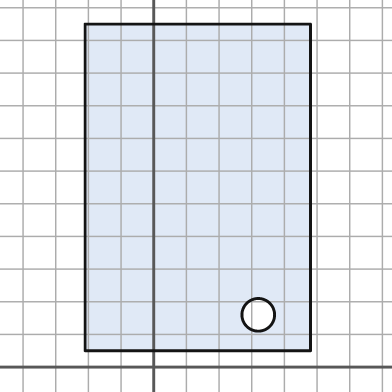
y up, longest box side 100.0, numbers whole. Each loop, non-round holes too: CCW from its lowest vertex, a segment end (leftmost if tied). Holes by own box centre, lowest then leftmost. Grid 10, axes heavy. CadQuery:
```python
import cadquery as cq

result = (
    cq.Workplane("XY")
    .moveTo(-21.0, 5.0)
    .lineTo(48.0, 5.0)
    .lineTo(48.0, 105.0)
    .lineTo(-21.0, 105.0)
    .close()
    .moveTo(32.0, 16.0)
    .circle(5.0)
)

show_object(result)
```